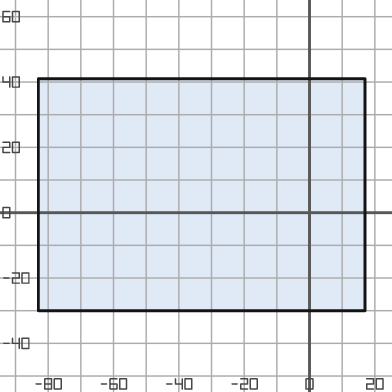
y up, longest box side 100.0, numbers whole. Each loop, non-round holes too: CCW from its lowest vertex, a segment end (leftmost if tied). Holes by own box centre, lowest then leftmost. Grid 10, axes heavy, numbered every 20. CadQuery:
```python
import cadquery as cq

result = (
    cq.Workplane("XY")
    .moveTo(-83.0, -30.0)
    .lineTo(17.0, -30.0)
    .lineTo(17.0, 41.0)
    .lineTo(-83.0, 41.0)
    .close()
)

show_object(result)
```